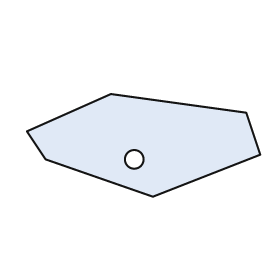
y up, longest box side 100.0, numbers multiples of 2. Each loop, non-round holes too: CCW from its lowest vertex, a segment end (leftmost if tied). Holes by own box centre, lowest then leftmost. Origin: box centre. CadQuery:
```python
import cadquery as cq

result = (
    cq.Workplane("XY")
    .moveTo(4.0, -22.0)
    .lineTo(50.0, -4.0)
    .lineTo(44.0, 14.0)
    .lineTo(-14.0, 22.0)
    .lineTo(-50.0, 6.0)
    .lineTo(-42.0, -6.0)
    .close()
    .moveTo(-4.0, -6.0)
    .circle(4.0)
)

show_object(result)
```